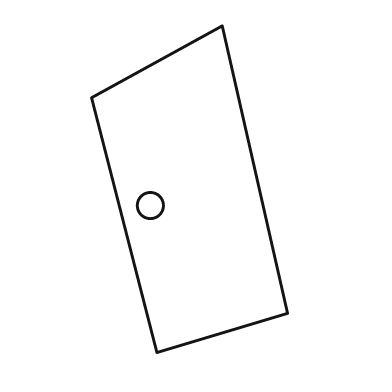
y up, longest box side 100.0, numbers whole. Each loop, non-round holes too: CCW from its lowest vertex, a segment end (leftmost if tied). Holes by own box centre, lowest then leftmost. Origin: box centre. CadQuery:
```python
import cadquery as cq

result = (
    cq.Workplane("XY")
    .moveTo(-10.0, -50.0)
    .lineTo(30.0, -38.0)
    .lineTo(10.0, 50.0)
    .lineTo(-30.0, 28.0)
    .close()
    .moveTo(-12.0, -5.0)
    .circle(4.0)
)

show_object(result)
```